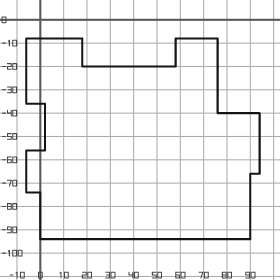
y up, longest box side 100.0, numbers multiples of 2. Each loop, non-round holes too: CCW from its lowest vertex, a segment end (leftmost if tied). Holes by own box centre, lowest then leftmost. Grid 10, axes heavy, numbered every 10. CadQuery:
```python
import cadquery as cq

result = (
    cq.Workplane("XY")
    .moveTo(0.0, -94.0)
    .lineTo(90.0, -94.0)
    .lineTo(90.0, -66.0)
    .lineTo(94.0, -66.0)
    .lineTo(94.0, -40.0)
    .lineTo(76.0, -40.0)
    .lineTo(76.0, -8.0)
    .lineTo(58.0, -8.0)
    .lineTo(58.0, -20.0)
    .lineTo(18.0, -20.0)
    .lineTo(18.0, -8.0)
    .lineTo(-6.0, -8.0)
    .lineTo(-6.0, -36.0)
    .lineTo(2.0, -36.0)
    .lineTo(2.0, -56.0)
    .lineTo(-6.0, -56.0)
    .lineTo(-6.0, -74.0)
    .lineTo(0.0, -74.0)
    .close()
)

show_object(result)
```